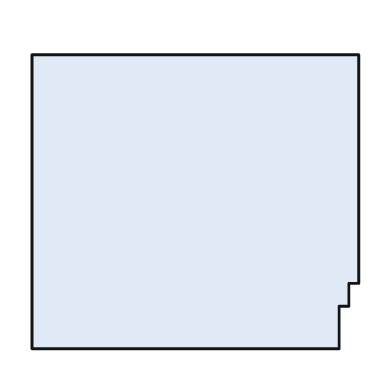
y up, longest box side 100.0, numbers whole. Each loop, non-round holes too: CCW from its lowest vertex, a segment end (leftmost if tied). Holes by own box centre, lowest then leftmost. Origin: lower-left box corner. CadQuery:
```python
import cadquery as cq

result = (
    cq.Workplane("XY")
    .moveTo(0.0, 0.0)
    .lineTo(94.0, 0.0)
    .lineTo(94.0, 13.0)
    .lineTo(97.0, 13.0)
    .lineTo(97.0, 20.0)
    .lineTo(100.0, 20.0)
    .lineTo(100.0, 90.0)
    .lineTo(0.0, 90.0)
    .close()
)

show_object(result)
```